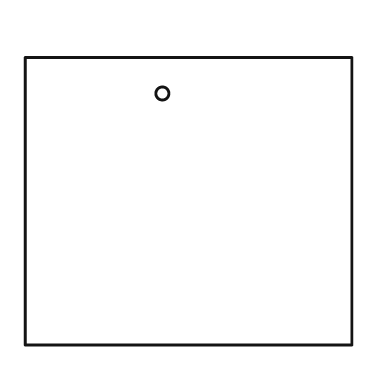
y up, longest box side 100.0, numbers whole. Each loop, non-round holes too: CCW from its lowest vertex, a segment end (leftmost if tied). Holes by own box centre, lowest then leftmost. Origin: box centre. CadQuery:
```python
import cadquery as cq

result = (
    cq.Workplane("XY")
    .moveTo(-50.0, -44.0)
    .lineTo(50.0, -44.0)
    .lineTo(50.0, 44.0)
    .lineTo(-50.0, 44.0)
    .close()
    .moveTo(-8.0, 33.0)
    .circle(2.0)
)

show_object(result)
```